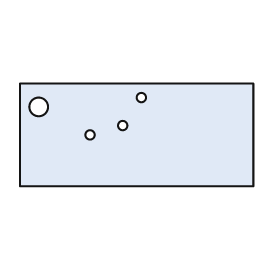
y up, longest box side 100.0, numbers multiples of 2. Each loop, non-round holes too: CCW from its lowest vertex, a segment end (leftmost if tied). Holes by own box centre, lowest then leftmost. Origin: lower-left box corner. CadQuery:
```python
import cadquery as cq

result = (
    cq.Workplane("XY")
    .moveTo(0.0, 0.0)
    .lineTo(100.0, 0.0)
    .lineTo(100.0, 44.0)
    .lineTo(0.0, 44.0)
    .close()
    .moveTo(30.0, 22.0)
    .circle(2.0)
    .moveTo(44.0, 26.0)
    .circle(2.0)
    .moveTo(8.0, 34.0)
    .circle(4.0)
    .moveTo(52.0, 38.0)
    .circle(2.0)
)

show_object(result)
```